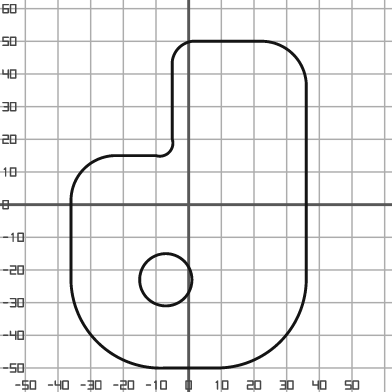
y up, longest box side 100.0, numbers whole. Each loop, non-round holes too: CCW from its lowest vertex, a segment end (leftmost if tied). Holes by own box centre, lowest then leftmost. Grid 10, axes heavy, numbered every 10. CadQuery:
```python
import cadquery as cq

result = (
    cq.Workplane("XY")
    .moveTo(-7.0, -50.0)
    .lineTo(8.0, -50.0)
    .threePointArc((28.0, -42.0), (36.0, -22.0))
    .lineTo(36.0, 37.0)
    .threePointArc((32.0, 46.0), (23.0, 50.0))
    .lineTo(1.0, 50.0)
    .threePointArc((-3.0, 48.0), (-5.0, 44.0))
    .lineTo(-5.0, 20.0)
    .threePointArc((-6.0, 16.0), (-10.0, 15.0))
    .lineTo(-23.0, 15.0)
    .threePointArc((-32.0, 11.0), (-36.0, 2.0))
    .lineTo(-36.0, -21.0)
    .threePointArc((-28.0, -42.0), (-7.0, -50.0))
    .close()
    .moveTo(-7.0, -23.0)
    .circle(8.0)
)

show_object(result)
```